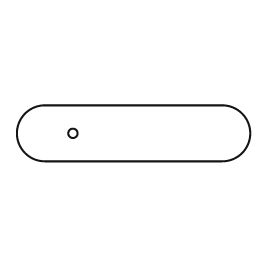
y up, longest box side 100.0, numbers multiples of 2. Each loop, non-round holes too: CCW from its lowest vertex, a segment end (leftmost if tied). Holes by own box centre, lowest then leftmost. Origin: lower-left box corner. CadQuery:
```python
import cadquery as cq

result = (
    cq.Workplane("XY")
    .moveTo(12.0, 0.0)
    .lineTo(88.0, 0.0)
    .threePointArc((100.0, 12.0), (88.0, 24.0))
    .lineTo(12.0, 24.0)
    .threePointArc((0.0, 12.0), (12.0, 0.0))
    .close()
    .moveTo(24.0, 12.0)
    .circle(2.0)
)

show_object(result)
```